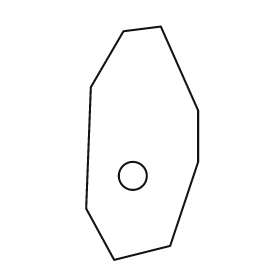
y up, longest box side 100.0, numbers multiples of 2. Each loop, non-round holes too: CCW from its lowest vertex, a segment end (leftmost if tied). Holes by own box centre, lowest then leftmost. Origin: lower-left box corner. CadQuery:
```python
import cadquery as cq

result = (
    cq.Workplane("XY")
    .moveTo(12.0, 0.0)
    .lineTo(36.0, 6.0)
    .lineTo(48.0, 42.0)
    .lineTo(48.0, 64.0)
    .lineTo(32.0, 100.0)
    .lineTo(16.0, 98.0)
    .lineTo(2.0, 74.0)
    .lineTo(0.0, 22.0)
    .close()
    .moveTo(20.0, 36.0)
    .circle(6.0)
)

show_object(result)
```